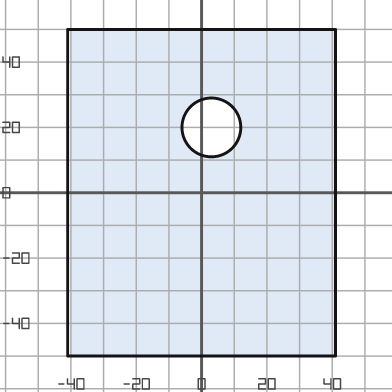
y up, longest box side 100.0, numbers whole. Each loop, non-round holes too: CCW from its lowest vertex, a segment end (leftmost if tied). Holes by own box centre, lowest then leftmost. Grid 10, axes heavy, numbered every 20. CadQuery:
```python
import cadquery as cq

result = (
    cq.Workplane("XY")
    .moveTo(-41.0, -50.0)
    .lineTo(41.0, -50.0)
    .lineTo(41.0, 50.0)
    .lineTo(-41.0, 50.0)
    .close()
    .moveTo(3.0, 20.0)
    .circle(9.0)
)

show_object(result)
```